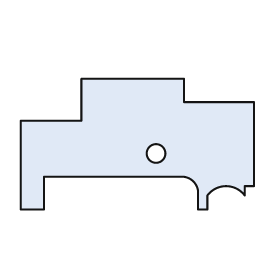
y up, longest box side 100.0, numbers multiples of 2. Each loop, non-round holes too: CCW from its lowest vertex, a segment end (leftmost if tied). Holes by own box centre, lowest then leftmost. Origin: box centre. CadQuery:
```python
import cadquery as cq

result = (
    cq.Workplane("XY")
    .moveTo(-50.0, -28.0)
    .lineTo(-40.0, -28.0)
    .lineTo(-40.0, -14.0)
    .lineTo(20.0, -14.0)
    .threePointArc((24.0, -16.0), (26.0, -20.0))
    .lineTo(26.0, -28.0)
    .lineTo(30.0, -28.0)
    .lineTo(30.0, -22.0)
    .threePointArc((38.0, -18.0), (46.0, -22.0))
    .lineTo(46.0, -18.0)
    .lineTo(50.0, -18.0)
    .lineTo(50.0, 18.0)
    .lineTo(20.0, 18.0)
    .lineTo(20.0, 28.0)
    .lineTo(-24.0, 28.0)
    .lineTo(-24.0, 10.0)
    .lineTo(-50.0, 10.0)
    .close()
    .moveTo(8.0, -4.0)
    .circle(4.0)
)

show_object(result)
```